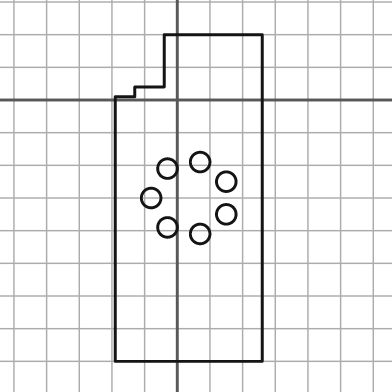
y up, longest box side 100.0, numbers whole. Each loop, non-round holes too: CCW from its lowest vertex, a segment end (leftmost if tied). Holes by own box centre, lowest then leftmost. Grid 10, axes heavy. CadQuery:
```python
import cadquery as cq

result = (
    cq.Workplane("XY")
    .moveTo(-19.0, -80.0)
    .lineTo(26.0, -80.0)
    .lineTo(26.0, 20.0)
    .lineTo(-4.0, 20.0)
    .lineTo(-4.0, 4.0)
    .lineTo(-13.0, 4.0)
    .lineTo(-13.0, 1.0)
    .lineTo(-19.0, 1.0)
    .close()
    .moveTo(7.0, -41.0)
    .circle(3.0)
    .moveTo(-3.0, -39.0)
    .circle(3.0)
    .moveTo(15.0, -35.0)
    .circle(3.0)
    .moveTo(-8.0, -30.0)
    .circle(3.0)
    .moveTo(15.0, -25.0)
    .circle(3.0)
    .moveTo(-3.0, -21.0)
    .circle(3.0)
    .moveTo(7.0, -19.0)
    .circle(3.0)
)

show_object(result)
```